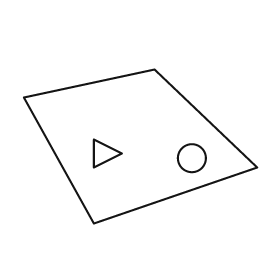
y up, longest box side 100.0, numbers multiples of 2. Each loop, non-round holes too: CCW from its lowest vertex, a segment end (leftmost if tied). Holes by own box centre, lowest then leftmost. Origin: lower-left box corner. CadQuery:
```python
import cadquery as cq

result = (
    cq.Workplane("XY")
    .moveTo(30.0, 0.0)
    .lineTo(100.0, 24.0)
    .lineTo(56.0, 66.0)
    .lineTo(0.0, 54.0)
    .close()
    .moveTo(72.0, 28.0)
    .circle(6.0)
    .moveTo(30.0, 24.0)
    .lineTo(42.0, 30.0)
    .lineTo(30.0, 36.0)
    .close()
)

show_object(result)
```